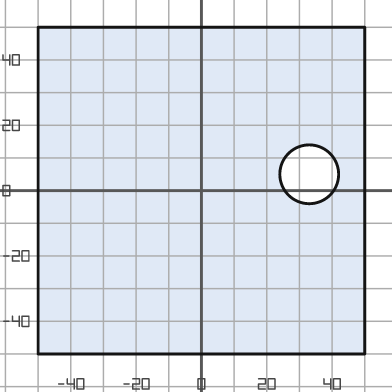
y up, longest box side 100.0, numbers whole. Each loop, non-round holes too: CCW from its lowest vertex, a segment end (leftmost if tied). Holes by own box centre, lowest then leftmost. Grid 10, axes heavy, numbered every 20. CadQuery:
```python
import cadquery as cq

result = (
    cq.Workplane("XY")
    .moveTo(-50.0, -50.0)
    .lineTo(50.0, -50.0)
    .lineTo(50.0, 50.0)
    .lineTo(-50.0, 50.0)
    .close()
    .moveTo(33.0, 5.0)
    .circle(9.0)
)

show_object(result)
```